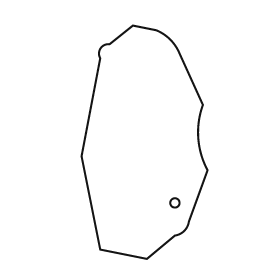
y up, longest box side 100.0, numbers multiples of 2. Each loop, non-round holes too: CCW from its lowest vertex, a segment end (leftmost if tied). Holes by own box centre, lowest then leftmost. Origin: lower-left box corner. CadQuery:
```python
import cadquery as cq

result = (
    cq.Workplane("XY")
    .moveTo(28.0, 0.0)
    .lineTo(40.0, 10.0)
    .threePointArc((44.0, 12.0), (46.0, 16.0))
    .lineTo(54.0, 38.0)
    .threePointArc((50.0, 52.0), (52.0, 66.0))
    .lineTo(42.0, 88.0)
    .threePointArc((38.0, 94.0), (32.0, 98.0))
    .lineTo(22.0, 100.0)
    .lineTo(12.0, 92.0)
    .threePointArc((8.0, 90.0), (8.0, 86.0))
    .lineTo(0.0, 44.0)
    .lineTo(8.0, 4.0)
    .close()
    .moveTo(40.0, 24.0)
    .circle(2.0)
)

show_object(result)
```